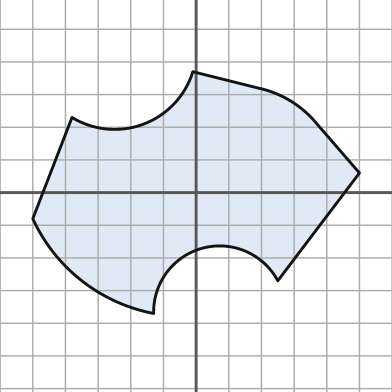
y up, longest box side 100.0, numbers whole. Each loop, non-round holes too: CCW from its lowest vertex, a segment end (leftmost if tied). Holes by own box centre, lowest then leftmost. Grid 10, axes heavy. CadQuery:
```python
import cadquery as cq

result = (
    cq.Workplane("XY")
    .moveTo(-13.0, -37.0)
    .threePointArc((2.0, -17.0), (25.0, -27.0))
    .lineTo(50.0, 6.0)
    .lineTo(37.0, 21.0)
    .threePointArc((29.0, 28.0), (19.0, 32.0))
    .lineTo(-1.0, 37.0)
    .threePointArc((-16.0, 21.0), (-38.0, 23.0))
    .lineTo(-50.0, -8.0)
    .threePointArc((-35.0, -27.0), (-13.0, -37.0))
    .close()
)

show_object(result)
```